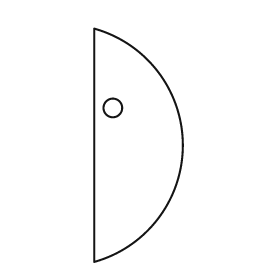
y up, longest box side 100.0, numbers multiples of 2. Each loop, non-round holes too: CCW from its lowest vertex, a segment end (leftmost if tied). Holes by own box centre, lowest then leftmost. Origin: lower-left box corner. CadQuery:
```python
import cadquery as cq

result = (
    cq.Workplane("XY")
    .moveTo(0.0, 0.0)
    .threePointArc((38.0, 50.0), (0.0, 100.0))
    .close()
    .moveTo(8.0, 66.0)
    .circle(4.0)
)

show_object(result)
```